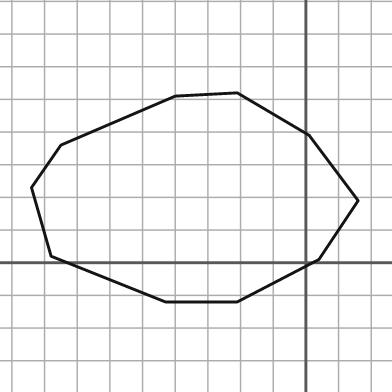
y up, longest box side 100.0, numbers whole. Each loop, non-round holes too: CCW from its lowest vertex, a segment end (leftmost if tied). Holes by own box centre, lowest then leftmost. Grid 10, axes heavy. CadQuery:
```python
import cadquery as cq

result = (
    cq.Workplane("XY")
    .moveTo(-43.0, -12.0)
    .lineTo(-21.0, -12.0)
    .lineTo(4.0, 1.0)
    .lineTo(16.0, 19.0)
    .lineTo(1.0, 39.0)
    .lineTo(-21.0, 52.0)
    .lineTo(-40.0, 51.0)
    .lineTo(-75.0, 36.0)
    .lineTo(-84.0, 23.0)
    .lineTo(-78.0, 2.0)
    .close()
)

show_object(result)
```